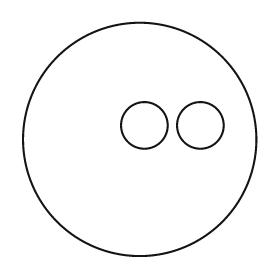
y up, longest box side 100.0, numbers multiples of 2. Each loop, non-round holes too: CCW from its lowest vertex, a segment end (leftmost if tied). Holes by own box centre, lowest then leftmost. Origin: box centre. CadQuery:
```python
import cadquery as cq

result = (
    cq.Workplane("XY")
    .moveTo(0.0, 0.0)
    .circle(50.0)
    .moveTo(2.0, 6.0)
    .circle(10.0)
    .moveTo(26.0, 6.0)
    .circle(10.0)
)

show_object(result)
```